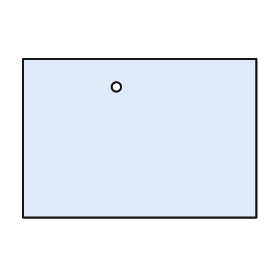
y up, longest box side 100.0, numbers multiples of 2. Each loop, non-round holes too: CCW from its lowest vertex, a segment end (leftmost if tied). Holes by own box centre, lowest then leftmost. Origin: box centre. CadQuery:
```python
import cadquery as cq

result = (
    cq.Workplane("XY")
    .moveTo(-50.0, -34.0)
    .lineTo(50.0, -34.0)
    .lineTo(50.0, 34.0)
    .lineTo(-50.0, 34.0)
    .close()
    .moveTo(-10.0, 22.0)
    .circle(2.0)
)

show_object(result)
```